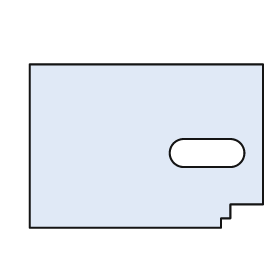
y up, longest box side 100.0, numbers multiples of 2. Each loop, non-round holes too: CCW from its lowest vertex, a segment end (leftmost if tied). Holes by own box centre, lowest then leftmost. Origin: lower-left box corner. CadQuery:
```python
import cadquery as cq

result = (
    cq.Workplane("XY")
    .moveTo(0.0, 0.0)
    .lineTo(82.0, 0.0)
    .lineTo(82.0, 4.0)
    .lineTo(86.0, 4.0)
    .lineTo(86.0, 10.0)
    .lineTo(100.0, 10.0)
    .lineTo(100.0, 70.0)
    .lineTo(0.0, 70.0)
    .close()
    .moveTo(66.0, 26.0)
    .lineTo(86.0, 26.0)
    .threePointArc((92.0, 32.0), (86.0, 38.0))
    .lineTo(66.0, 38.0)
    .threePointArc((60.0, 32.0), (66.0, 26.0))
    .close()
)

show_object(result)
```